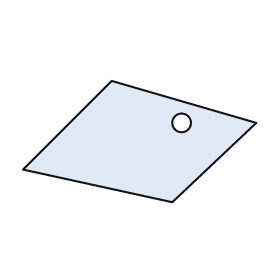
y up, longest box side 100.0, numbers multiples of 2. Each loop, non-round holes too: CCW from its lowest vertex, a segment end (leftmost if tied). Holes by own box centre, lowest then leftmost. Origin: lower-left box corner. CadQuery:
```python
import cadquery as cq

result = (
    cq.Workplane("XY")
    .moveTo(64.0, 0.0)
    .lineTo(100.0, 34.0)
    .lineTo(38.0, 52.0)
    .lineTo(0.0, 14.0)
    .close()
    .moveTo(68.0, 34.0)
    .circle(4.0)
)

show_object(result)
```